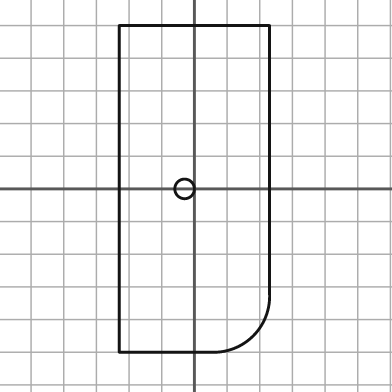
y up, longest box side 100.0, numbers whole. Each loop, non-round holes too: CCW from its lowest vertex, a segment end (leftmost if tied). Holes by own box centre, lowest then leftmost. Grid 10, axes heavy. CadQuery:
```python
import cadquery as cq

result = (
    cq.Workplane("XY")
    .moveTo(-23.0, -50.0)
    .lineTo(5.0, -50.0)
    .threePointArc((18.0, -45.0), (23.0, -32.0))
    .lineTo(23.0, 50.0)
    .lineTo(-23.0, 50.0)
    .close()
    .moveTo(-3.0, 0.0)
    .circle(3.0)
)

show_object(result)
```